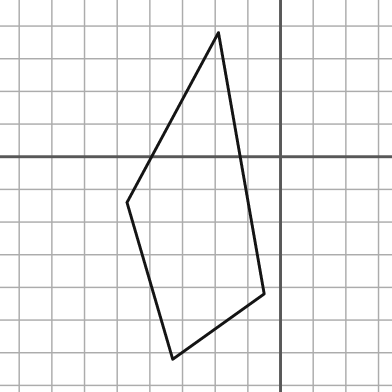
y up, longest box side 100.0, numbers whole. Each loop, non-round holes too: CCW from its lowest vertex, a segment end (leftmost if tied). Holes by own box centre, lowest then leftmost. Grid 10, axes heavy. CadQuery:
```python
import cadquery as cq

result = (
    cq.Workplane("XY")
    .moveTo(-33.0, -62.0)
    .lineTo(-5.0, -42.0)
    .lineTo(-19.0, 38.0)
    .lineTo(-47.0, -14.0)
    .close()
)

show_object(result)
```